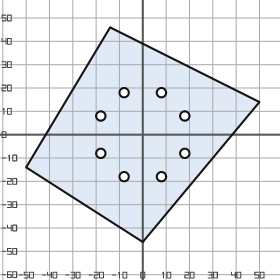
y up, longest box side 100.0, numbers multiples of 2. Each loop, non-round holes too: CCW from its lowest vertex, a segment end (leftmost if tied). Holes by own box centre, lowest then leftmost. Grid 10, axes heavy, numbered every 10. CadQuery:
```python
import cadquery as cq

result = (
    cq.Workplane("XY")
    .moveTo(0.0, -46.0)
    .lineTo(50.0, 14.0)
    .lineTo(-14.0, 46.0)
    .lineTo(-50.0, -14.0)
    .close()
    .moveTo(-8.0, -18.0)
    .circle(2.0)
    .moveTo(8.0, -18.0)
    .circle(2.0)
    .moveTo(-18.0, -8.0)
    .circle(2.0)
    .moveTo(18.0, -8.0)
    .circle(2.0)
    .moveTo(-18.0, 8.0)
    .circle(2.0)
    .moveTo(18.0, 8.0)
    .circle(2.0)
    .moveTo(-8.0, 18.0)
    .circle(2.0)
    .moveTo(8.0, 18.0)
    .circle(2.0)
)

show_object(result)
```